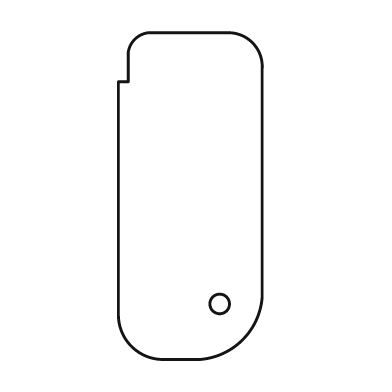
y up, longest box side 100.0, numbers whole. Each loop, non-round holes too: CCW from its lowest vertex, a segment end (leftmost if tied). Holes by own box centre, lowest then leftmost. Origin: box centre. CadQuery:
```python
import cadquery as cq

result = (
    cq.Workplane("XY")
    .moveTo(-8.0, -50.0)
    .lineTo(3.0, -50.0)
    .threePointArc((16.0, -44.0), (22.0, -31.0))
    .lineTo(22.0, 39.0)
    .threePointArc((19.0, 47.0), (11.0, 50.0))
    .lineTo(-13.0, 50.0)
    .threePointArc((-17.0, 48.0), (-19.0, 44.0))
    .lineTo(-19.0, 35.0)
    .lineTo(-22.0, 35.0)
    .lineTo(-22.0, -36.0)
    .threePointArc((-18.0, -46.0), (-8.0, -50.0))
    .close()
    .moveTo(9.0, -33.0)
    .circle(3.0)
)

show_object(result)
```